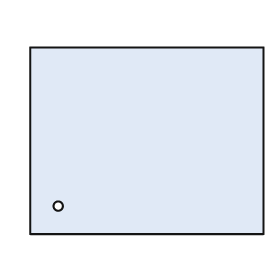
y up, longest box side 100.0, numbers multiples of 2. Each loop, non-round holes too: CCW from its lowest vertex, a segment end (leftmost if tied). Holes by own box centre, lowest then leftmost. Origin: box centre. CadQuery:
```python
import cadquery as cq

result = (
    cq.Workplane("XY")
    .moveTo(-50.0, -40.0)
    .lineTo(50.0, -40.0)
    .lineTo(50.0, 40.0)
    .lineTo(-50.0, 40.0)
    .close()
    .moveTo(-38.0, -28.0)
    .circle(2.0)
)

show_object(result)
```